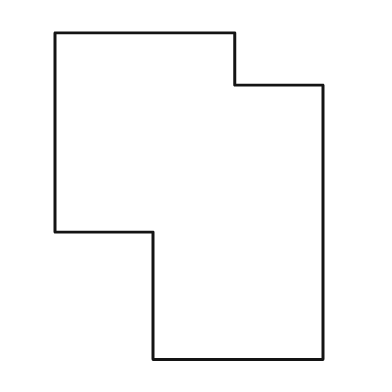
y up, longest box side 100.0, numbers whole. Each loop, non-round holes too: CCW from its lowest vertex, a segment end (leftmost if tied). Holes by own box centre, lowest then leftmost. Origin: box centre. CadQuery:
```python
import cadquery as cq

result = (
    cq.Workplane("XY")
    .moveTo(-11.0, -50.0)
    .lineTo(41.0, -50.0)
    .lineTo(41.0, 34.0)
    .lineTo(14.0, 34.0)
    .lineTo(14.0, 50.0)
    .lineTo(-41.0, 50.0)
    .lineTo(-41.0, -11.0)
    .lineTo(-11.0, -11.0)
    .close()
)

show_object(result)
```